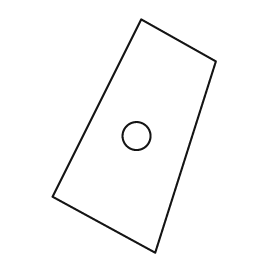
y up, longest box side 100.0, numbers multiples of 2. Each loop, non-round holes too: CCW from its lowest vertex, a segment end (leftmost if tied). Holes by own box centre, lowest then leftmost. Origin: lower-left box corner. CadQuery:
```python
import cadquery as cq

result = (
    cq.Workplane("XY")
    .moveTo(44.0, 0.0)
    .lineTo(70.0, 82.0)
    .lineTo(38.0, 100.0)
    .lineTo(0.0, 24.0)
    .close()
    .moveTo(36.0, 50.0)
    .circle(6.0)
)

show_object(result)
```